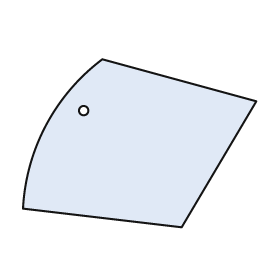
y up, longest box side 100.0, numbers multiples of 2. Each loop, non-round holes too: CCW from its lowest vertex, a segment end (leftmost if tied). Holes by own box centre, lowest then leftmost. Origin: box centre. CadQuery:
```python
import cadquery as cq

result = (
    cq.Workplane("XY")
    .moveTo(18.0, -36.0)
    .lineTo(50.0, 18.0)
    .lineTo(-16.0, 36.0)
    .threePointArc((-40.0, 8.0), (-50.0, -28.0))
    .close()
    .moveTo(-24.0, 14.0)
    .circle(2.0)
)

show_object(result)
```